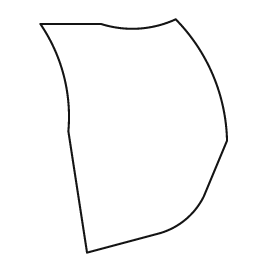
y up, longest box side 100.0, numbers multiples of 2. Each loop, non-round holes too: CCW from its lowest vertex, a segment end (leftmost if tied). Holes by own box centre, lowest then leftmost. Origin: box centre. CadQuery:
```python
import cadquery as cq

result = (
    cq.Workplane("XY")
    .moveTo(-20.0, -50.0)
    .lineTo(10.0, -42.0)
    .threePointArc((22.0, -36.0), (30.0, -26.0))
    .lineTo(40.0, -2.0)
    .threePointArc((34.0, 26.0), (18.0, 50.0))
    .threePointArc((2.0, 46.0), (-14.0, 48.0))
    .lineTo(-40.0, 48.0)
    .threePointArc((-30.0, 26.0), (-28.0, 2.0))
    .close()
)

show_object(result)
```